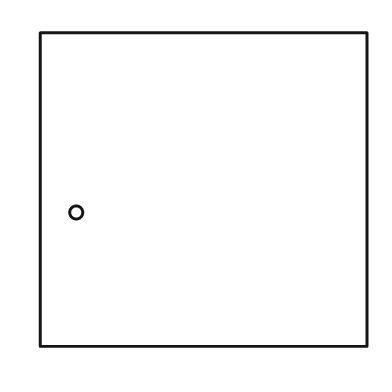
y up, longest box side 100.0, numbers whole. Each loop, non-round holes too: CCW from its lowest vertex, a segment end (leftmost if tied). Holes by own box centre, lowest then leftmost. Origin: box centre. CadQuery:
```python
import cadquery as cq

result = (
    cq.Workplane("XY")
    .moveTo(-50.0, -48.0)
    .lineTo(50.0, -48.0)
    .lineTo(50.0, 48.0)
    .lineTo(-50.0, 48.0)
    .close()
    .moveTo(-39.0, -7.0)
    .circle(2.0)
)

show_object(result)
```